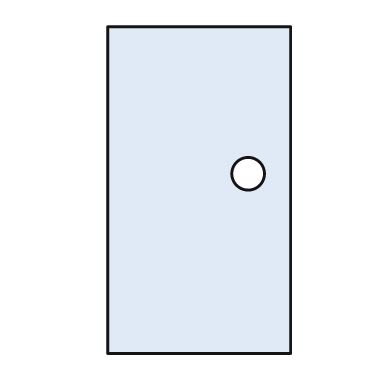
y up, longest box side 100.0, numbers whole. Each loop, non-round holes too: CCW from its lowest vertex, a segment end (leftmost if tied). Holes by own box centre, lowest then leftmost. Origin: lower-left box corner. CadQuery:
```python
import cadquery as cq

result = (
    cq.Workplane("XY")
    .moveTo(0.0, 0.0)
    .lineTo(56.0, 0.0)
    .lineTo(56.0, 100.0)
    .lineTo(0.0, 100.0)
    .close()
    .moveTo(43.0, 55.0)
    .circle(5.0)
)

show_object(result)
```